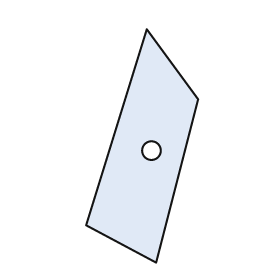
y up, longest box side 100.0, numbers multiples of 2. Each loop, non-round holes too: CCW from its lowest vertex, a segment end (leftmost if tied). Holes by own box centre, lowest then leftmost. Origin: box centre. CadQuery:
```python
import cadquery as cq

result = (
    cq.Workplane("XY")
    .moveTo(6.0, -50.0)
    .lineTo(24.0, 20.0)
    .lineTo(2.0, 50.0)
    .lineTo(-24.0, -34.0)
    .close()
    .moveTo(4.0, -2.0)
    .circle(4.0)
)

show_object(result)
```